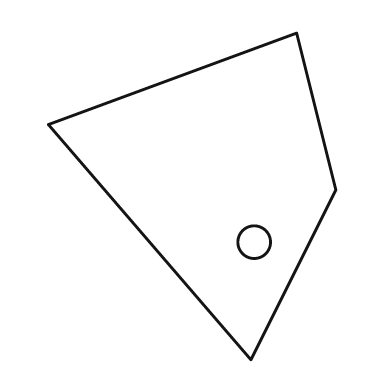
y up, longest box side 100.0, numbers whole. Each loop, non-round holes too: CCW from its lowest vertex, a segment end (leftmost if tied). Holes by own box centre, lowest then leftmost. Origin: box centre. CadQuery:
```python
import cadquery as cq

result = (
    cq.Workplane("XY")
    .moveTo(18.0, -50.0)
    .lineTo(44.0, 2.0)
    .lineTo(32.0, 50.0)
    .lineTo(-44.0, 22.0)
    .close()
    .moveTo(19.0, -14.0)
    .circle(5.0)
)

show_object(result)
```